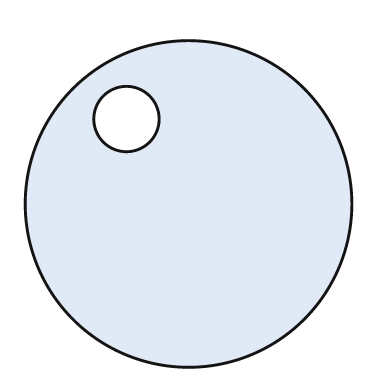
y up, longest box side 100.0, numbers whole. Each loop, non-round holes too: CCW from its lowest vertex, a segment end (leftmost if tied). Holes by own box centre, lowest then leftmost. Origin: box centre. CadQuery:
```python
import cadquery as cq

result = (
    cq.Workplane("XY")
    .moveTo(0.0, 0.0)
    .circle(50.0)
    .moveTo(-19.0, 26.0)
    .circle(10.0)
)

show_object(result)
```